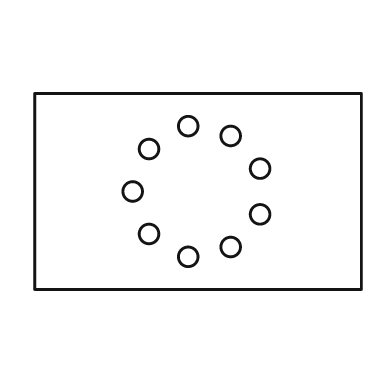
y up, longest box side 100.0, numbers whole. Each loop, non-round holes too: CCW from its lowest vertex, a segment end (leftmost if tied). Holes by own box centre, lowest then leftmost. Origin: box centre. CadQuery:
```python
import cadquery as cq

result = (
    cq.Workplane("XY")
    .moveTo(-50.0, -30.0)
    .lineTo(50.0, -30.0)
    .lineTo(50.0, 30.0)
    .lineTo(-50.0, 30.0)
    .close()
    .moveTo(-3.0, -20.0)
    .circle(3.0)
    .moveTo(10.0, -17.0)
    .circle(3.0)
    .moveTo(-15.0, -13.0)
    .circle(3.0)
    .moveTo(19.0, -7.0)
    .circle(3.0)
    .moveTo(-20.0, 0.0)
    .circle(3.0)
    .moveTo(19.0, 7.0)
    .circle(3.0)
    .moveTo(-15.0, 13.0)
    .circle(3.0)
    .moveTo(10.0, 17.0)
    .circle(3.0)
    .moveTo(-3.0, 20.0)
    .circle(3.0)
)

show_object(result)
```